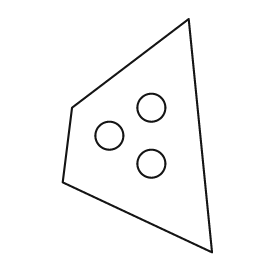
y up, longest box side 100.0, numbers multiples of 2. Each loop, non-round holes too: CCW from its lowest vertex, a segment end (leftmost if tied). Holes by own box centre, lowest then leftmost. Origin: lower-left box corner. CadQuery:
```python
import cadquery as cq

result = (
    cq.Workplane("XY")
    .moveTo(64.0, 0.0)
    .lineTo(54.0, 100.0)
    .lineTo(4.0, 62.0)
    .lineTo(0.0, 30.0)
    .close()
    .moveTo(38.0, 38.0)
    .circle(6.0)
    .moveTo(20.0, 50.0)
    .circle(6.0)
    .moveTo(38.0, 62.0)
    .circle(6.0)
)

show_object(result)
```